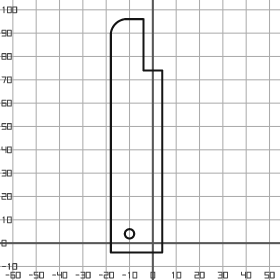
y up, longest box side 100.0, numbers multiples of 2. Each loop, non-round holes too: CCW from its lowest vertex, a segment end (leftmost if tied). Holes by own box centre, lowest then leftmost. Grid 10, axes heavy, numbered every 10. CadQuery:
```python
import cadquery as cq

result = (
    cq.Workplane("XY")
    .moveTo(-18.0, -4.0)
    .lineTo(4.0, -4.0)
    .lineTo(4.0, 74.0)
    .lineTo(-4.0, 74.0)
    .lineTo(-4.0, 96.0)
    .lineTo(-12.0, 96.0)
    .threePointArc((-16.0, 94.0), (-18.0, 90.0))
    .close()
    .moveTo(-10.0, 4.0)
    .circle(2.0)
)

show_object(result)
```